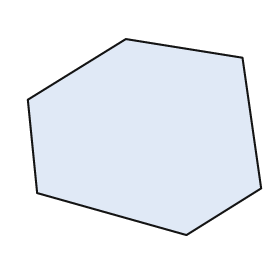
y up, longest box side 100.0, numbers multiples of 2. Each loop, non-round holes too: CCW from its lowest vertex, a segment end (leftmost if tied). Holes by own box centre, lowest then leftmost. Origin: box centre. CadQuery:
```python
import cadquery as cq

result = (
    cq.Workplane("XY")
    .moveTo(18.0, -42.0)
    .lineTo(50.0, -22.0)
    .lineTo(42.0, 34.0)
    .lineTo(-8.0, 42.0)
    .lineTo(-50.0, 16.0)
    .lineTo(-46.0, -24.0)
    .close()
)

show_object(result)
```